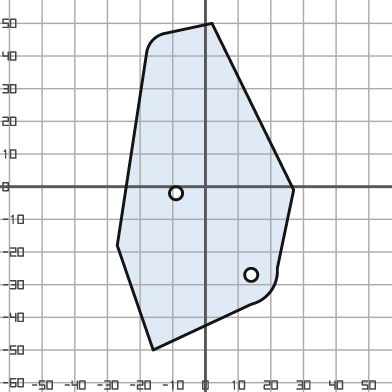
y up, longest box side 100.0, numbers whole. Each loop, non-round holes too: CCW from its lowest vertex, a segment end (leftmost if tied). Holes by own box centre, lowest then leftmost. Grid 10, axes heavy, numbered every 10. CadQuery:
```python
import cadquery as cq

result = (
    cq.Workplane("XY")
    .moveTo(-16.0, -50.0)
    .lineTo(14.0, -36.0)
    .threePointArc((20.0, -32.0), (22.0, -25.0))
    .lineTo(27.0, -1.0)
    .lineTo(2.0, 50.0)
    .lineTo(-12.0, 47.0)
    .threePointArc((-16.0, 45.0), (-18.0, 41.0))
    .lineTo(-27.0, -18.0)
    .close()
    .moveTo(14.0, -27.0)
    .circle(2.0)
    .moveTo(-9.0, -2.0)
    .circle(2.0)
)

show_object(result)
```